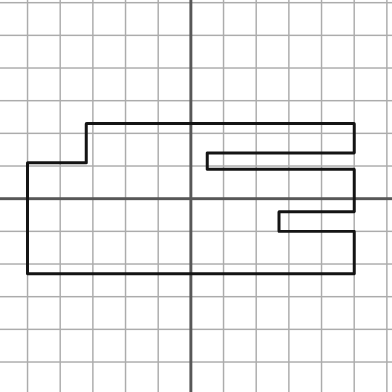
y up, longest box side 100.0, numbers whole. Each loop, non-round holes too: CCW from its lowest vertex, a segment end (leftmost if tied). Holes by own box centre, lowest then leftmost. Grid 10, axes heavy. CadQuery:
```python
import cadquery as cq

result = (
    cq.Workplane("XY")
    .moveTo(-50.0, -23.0)
    .lineTo(50.0, -23.0)
    .lineTo(50.0, -10.0)
    .lineTo(27.0, -10.0)
    .lineTo(27.0, -4.0)
    .lineTo(50.0, -4.0)
    .lineTo(50.0, 9.0)
    .lineTo(5.0, 9.0)
    .lineTo(5.0, 14.0)
    .lineTo(50.0, 14.0)
    .lineTo(50.0, 23.0)
    .lineTo(-32.0, 23.0)
    .lineTo(-32.0, 11.0)
    .lineTo(-50.0, 11.0)
    .close()
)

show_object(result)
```